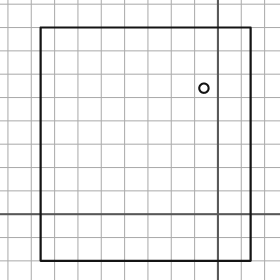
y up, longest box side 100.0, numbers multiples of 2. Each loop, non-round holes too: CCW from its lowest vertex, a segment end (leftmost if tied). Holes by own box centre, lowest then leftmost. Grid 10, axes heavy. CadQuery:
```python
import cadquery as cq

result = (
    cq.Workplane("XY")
    .moveTo(-76.0, -20.0)
    .lineTo(14.0, -20.0)
    .lineTo(14.0, 80.0)
    .lineTo(-76.0, 80.0)
    .close()
    .moveTo(-6.0, 54.0)
    .circle(2.0)
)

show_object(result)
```